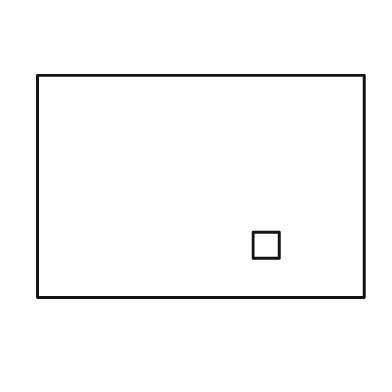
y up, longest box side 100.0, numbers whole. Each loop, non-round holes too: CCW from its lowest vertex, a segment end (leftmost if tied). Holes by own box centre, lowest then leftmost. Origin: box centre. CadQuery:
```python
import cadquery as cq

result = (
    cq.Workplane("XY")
    .moveTo(-50.0, -34.0)
    .lineTo(50.0, -34.0)
    .lineTo(50.0, 34.0)
    .lineTo(-50.0, 34.0)
    .close()
    .moveTo(16.0, -22.0)
    .lineTo(24.0, -22.0)
    .lineTo(24.0, -14.0)
    .lineTo(16.0, -14.0)
    .close()
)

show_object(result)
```